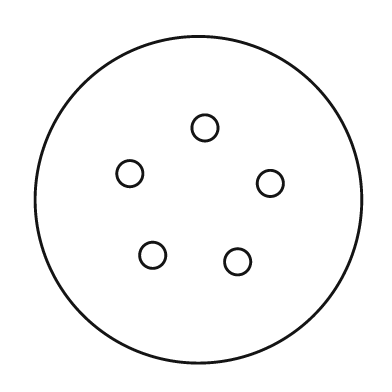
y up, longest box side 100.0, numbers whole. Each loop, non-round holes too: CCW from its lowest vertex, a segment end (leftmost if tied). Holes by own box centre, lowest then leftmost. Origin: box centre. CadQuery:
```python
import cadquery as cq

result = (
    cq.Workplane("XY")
    .moveTo(0.0, 0.0)
    .circle(50.0)
    .moveTo(12.0, -19.0)
    .circle(4.0)
    .moveTo(-14.0, -17.0)
    .circle(4.0)
    .moveTo(22.0, 5.0)
    .circle(4.0)
    .moveTo(-21.0, 8.0)
    .circle(4.0)
    .moveTo(2.0, 22.0)
    .circle(4.0)
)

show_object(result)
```